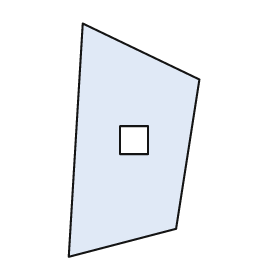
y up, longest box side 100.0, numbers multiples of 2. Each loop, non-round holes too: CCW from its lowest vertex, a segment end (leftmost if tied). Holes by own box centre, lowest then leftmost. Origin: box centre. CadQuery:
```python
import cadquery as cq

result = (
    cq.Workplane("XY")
    .moveTo(-28.0, -50.0)
    .lineTo(18.0, -38.0)
    .lineTo(28.0, 26.0)
    .lineTo(-22.0, 50.0)
    .close()
    .moveTo(-6.0, -6.0)
    .lineTo(6.0, -6.0)
    .lineTo(6.0, 6.0)
    .lineTo(-6.0, 6.0)
    .close()
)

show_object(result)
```